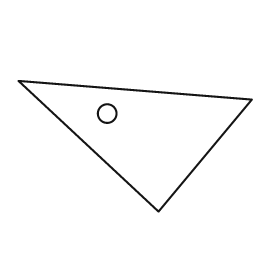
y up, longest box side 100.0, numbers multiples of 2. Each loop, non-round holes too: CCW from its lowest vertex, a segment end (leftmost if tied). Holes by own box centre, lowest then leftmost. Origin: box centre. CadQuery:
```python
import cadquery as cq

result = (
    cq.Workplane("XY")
    .moveTo(10.0, -28.0)
    .lineTo(50.0, 20.0)
    .lineTo(-50.0, 28.0)
    .close()
    .moveTo(-12.0, 14.0)
    .circle(4.0)
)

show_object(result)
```